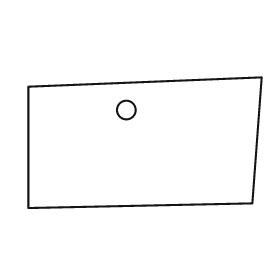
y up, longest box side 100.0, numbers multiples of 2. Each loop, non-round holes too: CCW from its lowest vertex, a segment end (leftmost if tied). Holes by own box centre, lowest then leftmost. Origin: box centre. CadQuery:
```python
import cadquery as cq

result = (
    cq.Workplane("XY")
    .moveTo(-50.0, -28.0)
    .lineTo(46.0, -26.0)
    .lineTo(50.0, 28.0)
    .lineTo(-50.0, 24.0)
    .close()
    .moveTo(-8.0, 14.0)
    .circle(4.0)
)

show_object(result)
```